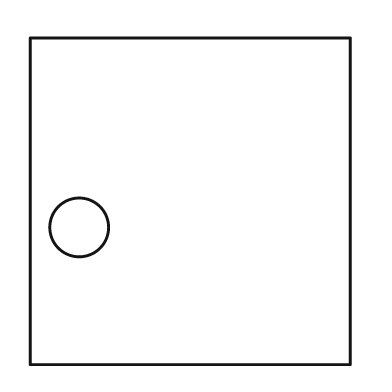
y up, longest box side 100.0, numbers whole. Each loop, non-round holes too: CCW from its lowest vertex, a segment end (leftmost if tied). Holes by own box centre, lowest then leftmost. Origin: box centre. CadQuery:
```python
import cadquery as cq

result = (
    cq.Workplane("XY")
    .moveTo(-49.0, -50.0)
    .lineTo(49.0, -50.0)
    .lineTo(49.0, 50.0)
    .lineTo(-49.0, 50.0)
    .close()
    .moveTo(-34.0, -8.0)
    .circle(9.0)
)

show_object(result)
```